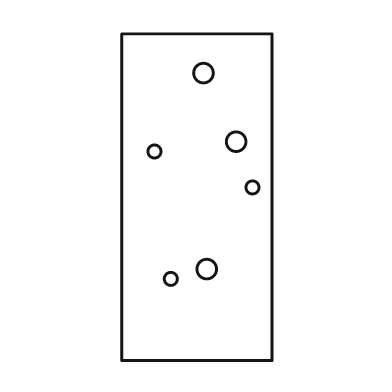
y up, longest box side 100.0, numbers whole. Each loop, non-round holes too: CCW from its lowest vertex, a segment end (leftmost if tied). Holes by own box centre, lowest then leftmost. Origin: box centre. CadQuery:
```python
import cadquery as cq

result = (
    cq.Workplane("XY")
    .moveTo(-23.0, -50.0)
    .lineTo(23.0, -50.0)
    .lineTo(23.0, 50.0)
    .lineTo(-23.0, 50.0)
    .close()
    .moveTo(-8.0, -25.0)
    .circle(2.0)
    .moveTo(3.0, -22.0)
    .circle(3.0)
    .moveTo(17.0, 3.0)
    .circle(2.0)
    .moveTo(-13.0, 14.0)
    .circle(2.0)
    .moveTo(12.0, 17.0)
    .circle(3.0)
    .moveTo(2.0, 38.0)
    .circle(3.0)
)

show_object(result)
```